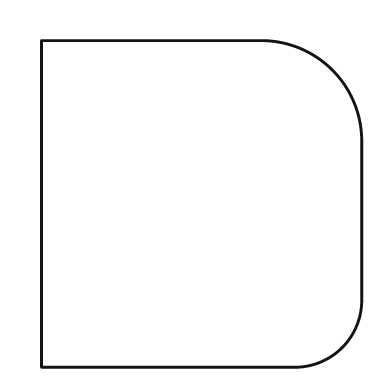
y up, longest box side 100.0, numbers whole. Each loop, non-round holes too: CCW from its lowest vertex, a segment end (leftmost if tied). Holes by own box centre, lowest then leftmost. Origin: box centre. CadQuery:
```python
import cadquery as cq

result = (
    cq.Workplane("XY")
    .moveTo(-49.0, -50.0)
    .lineTo(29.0, -50.0)
    .threePointArc((43.0, -44.0), (49.0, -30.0))
    .lineTo(49.0, 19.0)
    .threePointArc((40.0, 41.0), (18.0, 50.0))
    .lineTo(-49.0, 50.0)
    .close()
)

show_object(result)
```